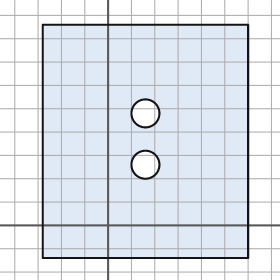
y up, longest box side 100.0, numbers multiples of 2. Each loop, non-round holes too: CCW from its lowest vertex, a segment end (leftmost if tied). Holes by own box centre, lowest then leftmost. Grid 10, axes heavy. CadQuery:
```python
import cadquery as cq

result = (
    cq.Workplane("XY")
    .moveTo(-28.0, -14.0)
    .lineTo(60.0, -14.0)
    .lineTo(60.0, 86.0)
    .lineTo(-28.0, 86.0)
    .close()
    .moveTo(16.0, 26.0)
    .circle(6.0)
    .moveTo(16.0, 48.0)
    .circle(6.0)
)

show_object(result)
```